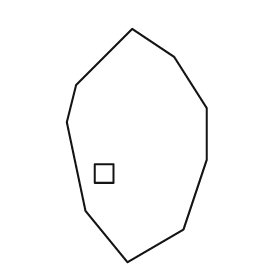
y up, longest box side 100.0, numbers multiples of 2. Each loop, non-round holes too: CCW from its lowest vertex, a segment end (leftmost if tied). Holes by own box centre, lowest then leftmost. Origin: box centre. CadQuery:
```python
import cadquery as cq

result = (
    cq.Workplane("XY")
    .moveTo(-4.0, -50.0)
    .lineTo(20.0, -36.0)
    .lineTo(30.0, -6.0)
    .lineTo(30.0, 16.0)
    .lineTo(16.0, 38.0)
    .lineTo(-2.0, 50.0)
    .lineTo(-26.0, 26.0)
    .lineTo(-30.0, 10.0)
    .lineTo(-22.0, -28.0)
    .close()
    .moveTo(-18.0, -16.0)
    .lineTo(-10.0, -16.0)
    .lineTo(-10.0, -8.0)
    .lineTo(-18.0, -8.0)
    .close()
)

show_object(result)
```